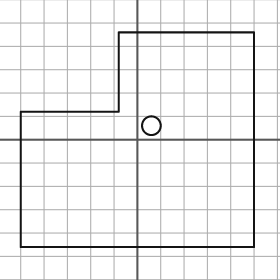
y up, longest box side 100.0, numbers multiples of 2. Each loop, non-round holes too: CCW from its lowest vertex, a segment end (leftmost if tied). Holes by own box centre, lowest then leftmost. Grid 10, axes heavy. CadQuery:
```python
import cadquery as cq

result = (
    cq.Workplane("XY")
    .moveTo(-50.0, -46.0)
    .lineTo(50.0, -46.0)
    .lineTo(50.0, 46.0)
    .lineTo(-8.0, 46.0)
    .lineTo(-8.0, 12.0)
    .lineTo(-50.0, 12.0)
    .close()
    .moveTo(6.0, 6.0)
    .circle(4.0)
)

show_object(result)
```